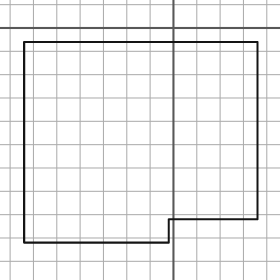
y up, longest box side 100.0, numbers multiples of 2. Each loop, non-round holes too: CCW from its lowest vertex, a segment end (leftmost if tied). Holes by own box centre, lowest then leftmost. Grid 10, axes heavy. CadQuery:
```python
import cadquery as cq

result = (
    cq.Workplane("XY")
    .moveTo(-64.0, -92.0)
    .lineTo(-2.0, -92.0)
    .lineTo(-2.0, -82.0)
    .lineTo(36.0, -82.0)
    .lineTo(36.0, -6.0)
    .lineTo(-64.0, -6.0)
    .close()
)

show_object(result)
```